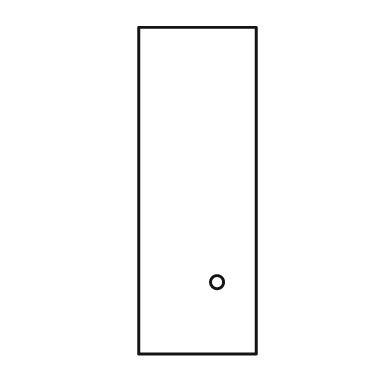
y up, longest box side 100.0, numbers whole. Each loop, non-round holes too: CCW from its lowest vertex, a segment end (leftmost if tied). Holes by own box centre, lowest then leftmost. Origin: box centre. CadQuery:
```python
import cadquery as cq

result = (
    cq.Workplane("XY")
    .moveTo(-18.0, -50.0)
    .lineTo(18.0, -50.0)
    .lineTo(18.0, 50.0)
    .lineTo(-18.0, 50.0)
    .close()
    .moveTo(6.0, -28.0)
    .circle(2.0)
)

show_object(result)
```